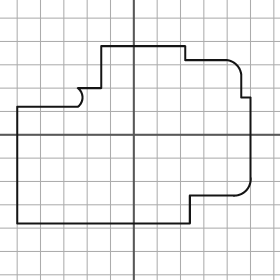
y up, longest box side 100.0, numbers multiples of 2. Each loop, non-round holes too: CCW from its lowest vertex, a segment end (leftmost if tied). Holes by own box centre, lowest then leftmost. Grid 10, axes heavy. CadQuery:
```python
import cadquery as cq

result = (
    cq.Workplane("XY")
    .moveTo(-50.0, -38.0)
    .lineTo(24.0, -38.0)
    .lineTo(24.0, -26.0)
    .lineTo(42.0, -26.0)
    .threePointArc((48.0, -24.0), (50.0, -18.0))
    .lineTo(50.0, 16.0)
    .lineTo(46.0, 16.0)
    .lineTo(46.0, 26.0)
    .threePointArc((44.0, 30.0), (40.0, 32.0))
    .lineTo(22.0, 32.0)
    .lineTo(22.0, 38.0)
    .lineTo(-14.0, 38.0)
    .lineTo(-14.0, 20.0)
    .lineTo(-24.0, 20.0)
    .threePointArc((-22.0, 16.0), (-24.0, 12.0))
    .lineTo(-50.0, 12.0)
    .close()
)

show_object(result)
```